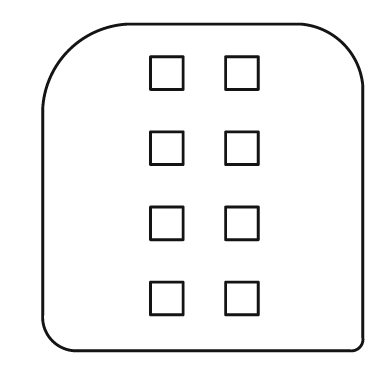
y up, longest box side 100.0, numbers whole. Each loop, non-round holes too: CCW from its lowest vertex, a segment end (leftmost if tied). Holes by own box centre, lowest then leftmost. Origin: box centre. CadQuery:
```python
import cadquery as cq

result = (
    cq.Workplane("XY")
    .moveTo(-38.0, -50.0)
    .lineTo(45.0, -50.0)
    .threePointArc((48.0, -49.0), (49.0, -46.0))
    .lineTo(49.0, 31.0)
    .threePointArc((43.0, 44.0), (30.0, 50.0))
    .lineTo(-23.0, 50.0)
    .threePointArc((-41.0, 42.0), (-49.0, 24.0))
    .lineTo(-49.0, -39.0)
    .threePointArc((-46.0, -47.0), (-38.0, -50.0))
    .close()
    .moveTo(-16.0, -39.0)
    .lineTo(-6.0, -39.0)
    .lineTo(-6.0, -29.0)
    .lineTo(-16.0, -29.0)
    .close()
    .moveTo(7.0, -39.0)
    .lineTo(17.0, -39.0)
    .lineTo(17.0, -29.0)
    .lineTo(7.0, -29.0)
    .close()
    .moveTo(-16.0, -16.0)
    .lineTo(-6.0, -16.0)
    .lineTo(-6.0, -6.0)
    .lineTo(-16.0, -6.0)
    .close()
    .moveTo(7.0, -16.0)
    .lineTo(17.0, -16.0)
    .lineTo(17.0, -6.0)
    .lineTo(7.0, -6.0)
    .close()
    .moveTo(-16.0, 7.0)
    .lineTo(-6.0, 7.0)
    .lineTo(-6.0, 17.0)
    .lineTo(-16.0, 17.0)
    .close()
    .moveTo(7.0, 7.0)
    .lineTo(17.0, 7.0)
    .lineTo(17.0, 17.0)
    .lineTo(7.0, 17.0)
    .close()
    .moveTo(-16.0, 30.0)
    .lineTo(-6.0, 30.0)
    .lineTo(-6.0, 40.0)
    .lineTo(-16.0, 40.0)
    .close()
    .moveTo(7.0, 30.0)
    .lineTo(17.0, 30.0)
    .lineTo(17.0, 40.0)
    .lineTo(7.0, 40.0)
    .close()
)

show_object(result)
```